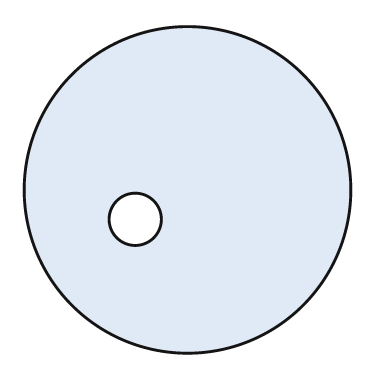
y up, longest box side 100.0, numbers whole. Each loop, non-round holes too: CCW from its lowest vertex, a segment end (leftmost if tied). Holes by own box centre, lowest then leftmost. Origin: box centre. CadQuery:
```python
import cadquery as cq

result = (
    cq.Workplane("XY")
    .moveTo(0.0, 0.0)
    .circle(50.0)
    .moveTo(-16.0, -9.0)
    .circle(8.0)
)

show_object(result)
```